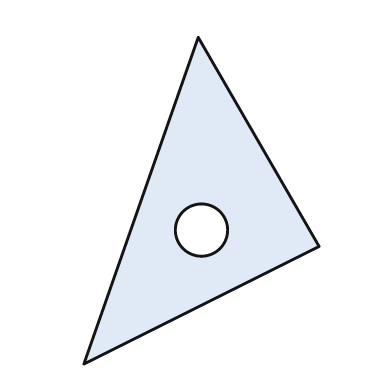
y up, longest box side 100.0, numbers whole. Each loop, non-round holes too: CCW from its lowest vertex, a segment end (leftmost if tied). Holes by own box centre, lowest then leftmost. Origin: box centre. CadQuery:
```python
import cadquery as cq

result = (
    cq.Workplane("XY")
    .moveTo(-36.0, -50.0)
    .lineTo(36.0, -14.0)
    .lineTo(-1.0, 50.0)
    .close()
    .moveTo(0.0, -9.0)
    .circle(8.0)
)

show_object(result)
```